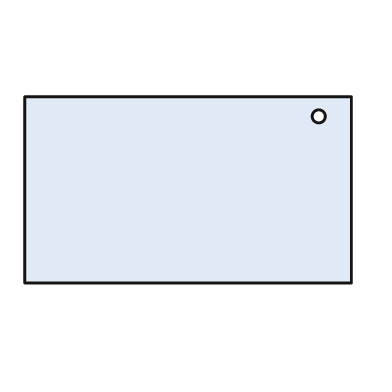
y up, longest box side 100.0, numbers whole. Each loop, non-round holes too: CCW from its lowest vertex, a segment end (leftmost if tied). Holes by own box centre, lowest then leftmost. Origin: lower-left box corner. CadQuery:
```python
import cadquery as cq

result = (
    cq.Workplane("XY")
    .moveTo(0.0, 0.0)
    .lineTo(100.0, 0.0)
    .lineTo(100.0, 57.0)
    .lineTo(0.0, 57.0)
    .close()
    .moveTo(90.0, 51.0)
    .circle(2.0)
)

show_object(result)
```